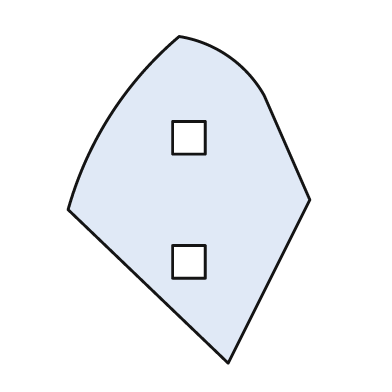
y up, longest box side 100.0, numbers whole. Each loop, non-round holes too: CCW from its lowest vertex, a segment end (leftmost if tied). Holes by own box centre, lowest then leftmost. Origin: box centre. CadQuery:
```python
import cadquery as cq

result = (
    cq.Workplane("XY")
    .moveTo(12.0, -50.0)
    .lineTo(37.0, 0.0)
    .lineTo(23.0, 32.0)
    .threePointArc((12.0, 44.0), (-3.0, 50.0))
    .threePointArc((-24.0, 26.0), (-37.0, -3.0))
    .close()
    .moveTo(-5.0, -24.0)
    .lineTo(5.0, -24.0)
    .lineTo(5.0, -14.0)
    .lineTo(-5.0, -14.0)
    .close()
    .moveTo(-5.0, 14.0)
    .lineTo(5.0, 14.0)
    .lineTo(5.0, 24.0)
    .lineTo(-5.0, 24.0)
    .close()
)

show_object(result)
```